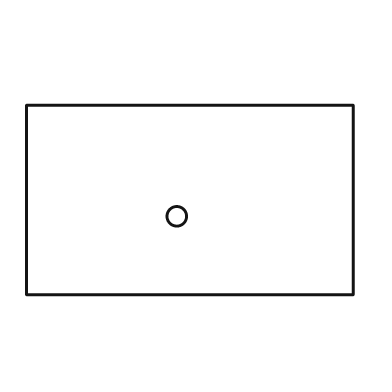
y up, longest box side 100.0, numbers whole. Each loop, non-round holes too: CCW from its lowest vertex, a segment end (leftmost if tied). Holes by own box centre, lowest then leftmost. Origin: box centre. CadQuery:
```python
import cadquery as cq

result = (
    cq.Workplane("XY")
    .moveTo(-50.0, -29.0)
    .lineTo(50.0, -29.0)
    .lineTo(50.0, 29.0)
    .lineTo(-50.0, 29.0)
    .close()
    .moveTo(-4.0, -5.0)
    .circle(3.0)
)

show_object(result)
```